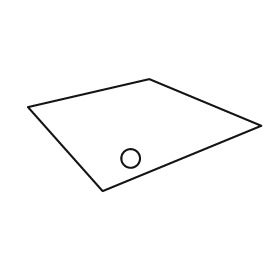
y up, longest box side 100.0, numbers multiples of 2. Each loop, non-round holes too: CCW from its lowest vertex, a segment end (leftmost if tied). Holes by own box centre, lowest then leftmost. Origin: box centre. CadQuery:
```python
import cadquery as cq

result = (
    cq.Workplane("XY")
    .moveTo(-18.0, -24.0)
    .lineTo(50.0, 4.0)
    .lineTo(2.0, 24.0)
    .lineTo(-50.0, 12.0)
    .close()
    .moveTo(-6.0, -10.0)
    .circle(4.0)
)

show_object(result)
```